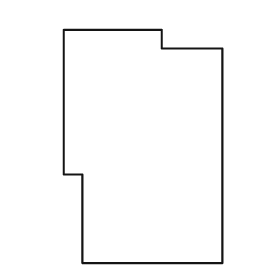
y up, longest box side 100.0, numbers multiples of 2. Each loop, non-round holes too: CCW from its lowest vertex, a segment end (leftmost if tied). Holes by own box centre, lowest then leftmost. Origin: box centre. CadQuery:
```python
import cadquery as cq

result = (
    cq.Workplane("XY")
    .moveTo(-26.0, -50.0)
    .lineTo(34.0, -50.0)
    .lineTo(34.0, 42.0)
    .lineTo(8.0, 42.0)
    .lineTo(8.0, 50.0)
    .lineTo(-34.0, 50.0)
    .lineTo(-34.0, -12.0)
    .lineTo(-26.0, -12.0)
    .close()
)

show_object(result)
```